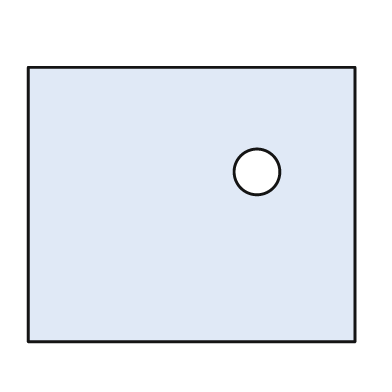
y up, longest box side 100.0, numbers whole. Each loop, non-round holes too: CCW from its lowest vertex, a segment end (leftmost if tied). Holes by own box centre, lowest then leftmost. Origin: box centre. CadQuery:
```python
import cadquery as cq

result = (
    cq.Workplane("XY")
    .moveTo(-50.0, -42.0)
    .lineTo(50.0, -42.0)
    .lineTo(50.0, 42.0)
    .lineTo(-50.0, 42.0)
    .close()
    .moveTo(20.0, 10.0)
    .circle(7.0)
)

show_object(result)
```